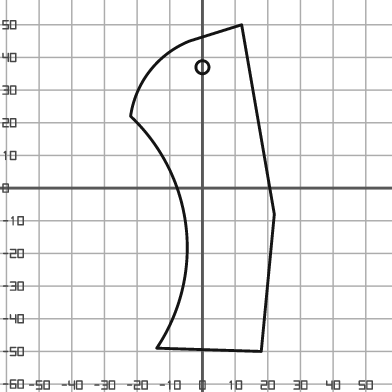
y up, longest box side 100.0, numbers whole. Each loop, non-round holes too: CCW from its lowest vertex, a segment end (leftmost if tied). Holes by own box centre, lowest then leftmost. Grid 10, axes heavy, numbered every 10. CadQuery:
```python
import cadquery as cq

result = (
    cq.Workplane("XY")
    .moveTo(18.0, -50.0)
    .lineTo(22.0, -8.0)
    .lineTo(12.0, 50.0)
    .lineTo(-4.0, 45.0)
    .threePointArc((-16.0, 36.0), (-22.0, 22.0))
    .threePointArc((-5.0, -12.0), (-14.0, -49.0))
    .close()
    .moveTo(0.0, 37.0)
    .circle(2.0)
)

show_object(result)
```